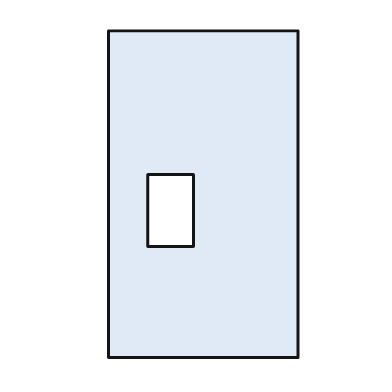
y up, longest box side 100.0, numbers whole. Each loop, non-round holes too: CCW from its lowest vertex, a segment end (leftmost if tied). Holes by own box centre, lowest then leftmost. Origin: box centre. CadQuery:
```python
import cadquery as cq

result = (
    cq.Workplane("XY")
    .moveTo(-29.0, -50.0)
    .lineTo(29.0, -50.0)
    .lineTo(29.0, 50.0)
    .lineTo(-29.0, 50.0)
    .close()
    .moveTo(-17.0, -16.0)
    .lineTo(-3.0, -16.0)
    .lineTo(-3.0, 6.0)
    .lineTo(-17.0, 6.0)
    .close()
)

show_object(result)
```